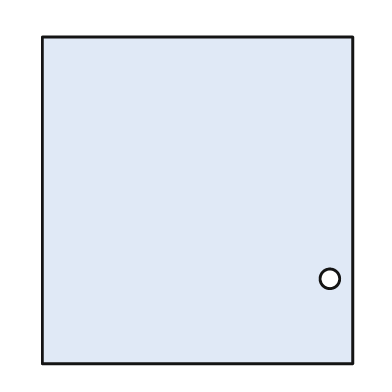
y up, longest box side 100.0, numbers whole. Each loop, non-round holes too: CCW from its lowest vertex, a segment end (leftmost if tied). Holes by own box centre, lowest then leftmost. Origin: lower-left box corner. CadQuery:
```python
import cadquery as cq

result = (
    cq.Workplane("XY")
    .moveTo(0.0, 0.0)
    .lineTo(95.0, 0.0)
    .lineTo(95.0, 100.0)
    .lineTo(0.0, 100.0)
    .close()
    .moveTo(88.0, 26.0)
    .circle(3.0)
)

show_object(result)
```